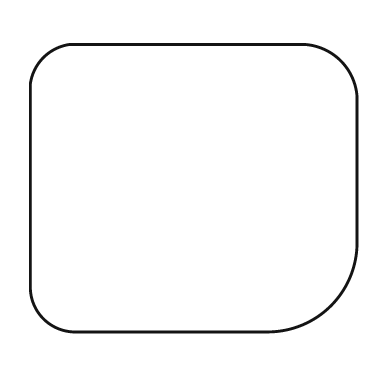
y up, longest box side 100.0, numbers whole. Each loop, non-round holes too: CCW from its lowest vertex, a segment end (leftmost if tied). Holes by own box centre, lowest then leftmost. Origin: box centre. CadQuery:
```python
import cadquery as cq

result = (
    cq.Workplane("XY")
    .moveTo(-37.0, -44.0)
    .lineTo(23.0, -44.0)
    .threePointArc((42.0, -36.0), (50.0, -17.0))
    .lineTo(50.0, 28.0)
    .threePointArc((45.0, 39.0), (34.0, 44.0))
    .lineTo(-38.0, 44.0)
    .threePointArc((-46.0, 40.0), (-50.0, 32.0))
    .lineTo(-50.0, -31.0)
    .threePointArc((-46.0, -40.0), (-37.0, -44.0))
    .close()
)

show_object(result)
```